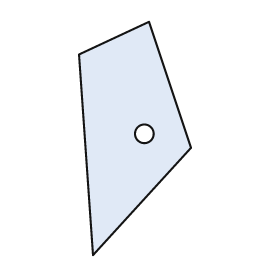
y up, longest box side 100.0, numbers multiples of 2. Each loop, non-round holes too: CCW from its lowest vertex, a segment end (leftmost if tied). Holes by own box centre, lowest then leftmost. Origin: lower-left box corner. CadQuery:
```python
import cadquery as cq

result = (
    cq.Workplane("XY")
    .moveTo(6.0, 0.0)
    .lineTo(48.0, 46.0)
    .lineTo(30.0, 100.0)
    .lineTo(0.0, 86.0)
    .close()
    .moveTo(28.0, 52.0)
    .circle(4.0)
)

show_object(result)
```